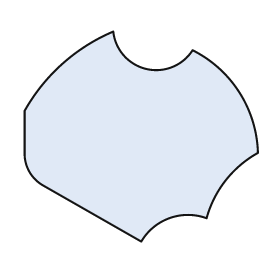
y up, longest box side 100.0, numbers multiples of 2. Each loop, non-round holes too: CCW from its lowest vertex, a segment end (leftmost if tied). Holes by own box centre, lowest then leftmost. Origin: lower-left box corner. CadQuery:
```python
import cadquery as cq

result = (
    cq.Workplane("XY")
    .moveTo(50.0, 0.0)
    .threePointArc((62.0, 10.0), (78.0, 10.0))
    .threePointArc((86.0, 26.0), (100.0, 38.0))
    .threePointArc((92.0, 64.0), (72.0, 82.0))
    .threePointArc((52.0, 74.0), (38.0, 90.0))
    .threePointArc((16.0, 76.0), (0.0, 56.0))
    .lineTo(0.0, 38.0)
    .threePointArc((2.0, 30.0), (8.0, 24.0))
    .close()
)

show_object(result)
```